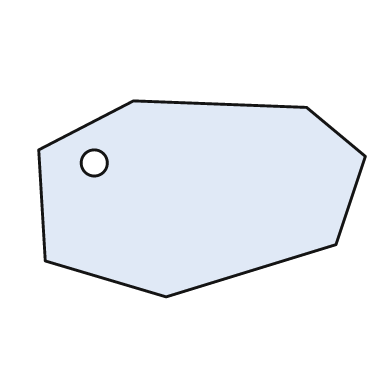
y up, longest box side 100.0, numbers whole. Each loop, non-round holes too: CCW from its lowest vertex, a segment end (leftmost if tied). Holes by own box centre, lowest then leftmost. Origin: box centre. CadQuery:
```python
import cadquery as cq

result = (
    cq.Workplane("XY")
    .moveTo(-11.0, -30.0)
    .lineTo(41.0, -14.0)
    .lineTo(50.0, 13.0)
    .lineTo(32.0, 28.0)
    .lineTo(-21.0, 30.0)
    .lineTo(-50.0, 15.0)
    .lineTo(-48.0, -19.0)
    .close()
    .moveTo(-33.0, 11.0)
    .circle(4.0)
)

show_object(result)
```